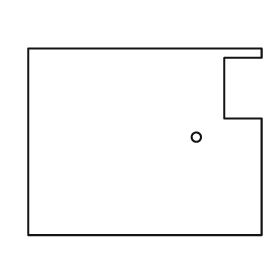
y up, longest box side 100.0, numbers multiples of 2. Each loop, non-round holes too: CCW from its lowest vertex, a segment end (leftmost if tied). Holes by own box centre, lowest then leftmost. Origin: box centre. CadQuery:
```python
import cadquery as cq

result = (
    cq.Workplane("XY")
    .moveTo(-50.0, -40.0)
    .lineTo(50.0, -40.0)
    .lineTo(50.0, 10.0)
    .lineTo(34.0, 10.0)
    .lineTo(34.0, 36.0)
    .lineTo(50.0, 36.0)
    .lineTo(50.0, 40.0)
    .lineTo(-50.0, 40.0)
    .close()
    .moveTo(22.0, 2.0)
    .circle(2.0)
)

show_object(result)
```